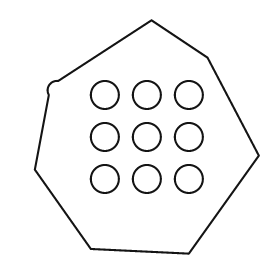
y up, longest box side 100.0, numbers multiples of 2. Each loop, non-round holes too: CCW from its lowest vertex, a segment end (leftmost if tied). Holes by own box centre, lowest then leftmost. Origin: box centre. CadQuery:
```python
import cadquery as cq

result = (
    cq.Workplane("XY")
    .moveTo(18.0, -50.0)
    .lineTo(48.0, -8.0)
    .lineTo(26.0, 34.0)
    .lineTo(2.0, 50.0)
    .lineTo(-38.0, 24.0)
    .threePointArc((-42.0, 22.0), (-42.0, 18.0))
    .lineTo(-48.0, -14.0)
    .lineTo(-24.0, -48.0)
    .close()
    .moveTo(-18.0, -18.0)
    .circle(6.0)
    .moveTo(0.0, -18.0)
    .circle(6.0)
    .moveTo(18.0, -18.0)
    .circle(6.0)
    .moveTo(-18.0, 0.0)
    .circle(6.0)
    .moveTo(0.0, 0.0)
    .circle(6.0)
    .moveTo(18.0, 0.0)
    .circle(6.0)
    .moveTo(-18.0, 18.0)
    .circle(6.0)
    .moveTo(0.0, 18.0)
    .circle(6.0)
    .moveTo(18.0, 18.0)
    .circle(6.0)
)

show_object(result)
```